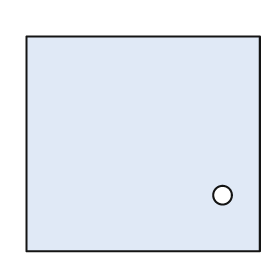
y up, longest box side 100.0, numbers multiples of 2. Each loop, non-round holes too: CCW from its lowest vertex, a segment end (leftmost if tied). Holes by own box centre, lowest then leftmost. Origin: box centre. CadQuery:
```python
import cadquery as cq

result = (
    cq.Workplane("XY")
    .moveTo(-50.0, -46.0)
    .lineTo(50.0, -46.0)
    .lineTo(50.0, 46.0)
    .lineTo(-50.0, 46.0)
    .close()
    .moveTo(34.0, -22.0)
    .circle(4.0)
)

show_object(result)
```